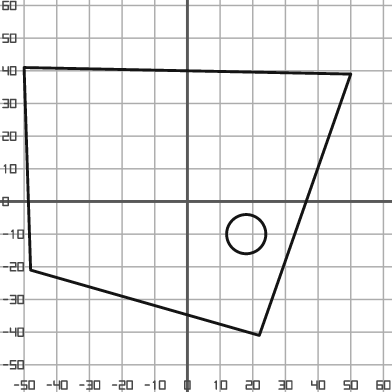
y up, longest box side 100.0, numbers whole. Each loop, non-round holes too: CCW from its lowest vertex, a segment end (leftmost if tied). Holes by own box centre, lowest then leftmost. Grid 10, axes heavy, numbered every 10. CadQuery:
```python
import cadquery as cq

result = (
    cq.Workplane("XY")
    .moveTo(22.0, -41.0)
    .lineTo(50.0, 39.0)
    .lineTo(-50.0, 41.0)
    .lineTo(-48.0, -21.0)
    .close()
    .moveTo(18.0, -10.0)
    .circle(6.0)
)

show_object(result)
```